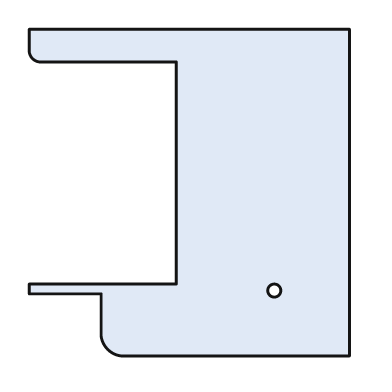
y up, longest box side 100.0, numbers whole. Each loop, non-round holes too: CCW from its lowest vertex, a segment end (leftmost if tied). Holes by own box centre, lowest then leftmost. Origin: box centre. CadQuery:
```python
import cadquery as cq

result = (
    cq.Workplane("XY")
    .moveTo(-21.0, -50.0)
    .lineTo(49.0, -50.0)
    .lineTo(49.0, 50.0)
    .lineTo(-49.0, 50.0)
    .lineTo(-49.0, 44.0)
    .threePointArc((-48.0, 41.0), (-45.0, 40.0))
    .lineTo(-4.0, 40.0)
    .lineTo(-4.0, -28.0)
    .lineTo(-49.0, -28.0)
    .lineTo(-49.0, -31.0)
    .lineTo(-27.0, -31.0)
    .lineTo(-27.0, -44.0)
    .threePointArc((-25.0, -48.0), (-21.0, -50.0))
    .close()
    .moveTo(26.0, -30.0)
    .circle(2.0)
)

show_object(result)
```